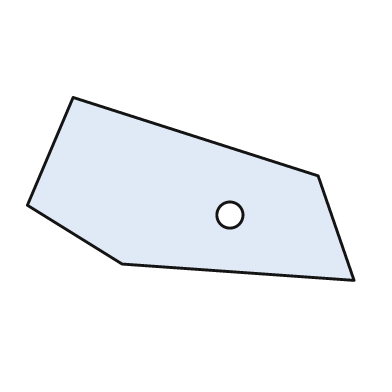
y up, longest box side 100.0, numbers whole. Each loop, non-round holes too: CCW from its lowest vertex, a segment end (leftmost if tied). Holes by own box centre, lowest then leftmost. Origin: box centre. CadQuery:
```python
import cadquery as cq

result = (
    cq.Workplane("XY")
    .moveTo(50.0, -28.0)
    .lineTo(39.0, 4.0)
    .lineTo(-36.0, 28.0)
    .lineTo(-50.0, -5.0)
    .lineTo(-21.0, -23.0)
    .close()
    .moveTo(12.0, -8.0)
    .circle(4.0)
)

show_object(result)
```